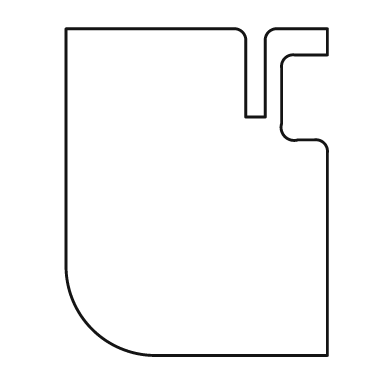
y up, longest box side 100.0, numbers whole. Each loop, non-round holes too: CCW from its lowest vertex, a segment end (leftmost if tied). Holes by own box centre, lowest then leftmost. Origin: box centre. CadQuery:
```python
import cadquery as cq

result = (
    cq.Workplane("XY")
    .moveTo(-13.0, -50.0)
    .lineTo(40.0, -50.0)
    .lineTo(40.0, 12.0)
    .threePointArc((39.0, 15.0), (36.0, 16.0))
    .lineTo(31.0, 16.0)
    .threePointArc((27.0, 17.0), (26.0, 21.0))
    .lineTo(26.0, 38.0)
    .threePointArc((27.0, 41.0), (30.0, 42.0))
    .lineTo(40.0, 42.0)
    .lineTo(40.0, 50.0)
    .lineTo(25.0, 50.0)
    .threePointArc((22.0, 49.0), (21.0, 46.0))
    .lineTo(21.0, 23.0)
    .lineTo(15.0, 23.0)
    .lineTo(15.0, 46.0)
    .threePointArc((14.0, 49.0), (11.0, 50.0))
    .lineTo(-40.0, 50.0)
    .lineTo(-40.0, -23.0)
    .threePointArc((-32.0, -42.0), (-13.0, -50.0))
    .close()
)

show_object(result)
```